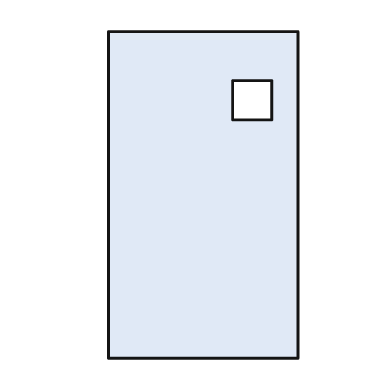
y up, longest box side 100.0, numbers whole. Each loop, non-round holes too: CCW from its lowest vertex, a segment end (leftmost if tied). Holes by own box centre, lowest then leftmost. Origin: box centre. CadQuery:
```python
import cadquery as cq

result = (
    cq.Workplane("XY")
    .moveTo(-29.0, -50.0)
    .lineTo(29.0, -50.0)
    .lineTo(29.0, 50.0)
    .lineTo(-29.0, 50.0)
    .close()
    .moveTo(9.0, 23.0)
    .lineTo(21.0, 23.0)
    .lineTo(21.0, 35.0)
    .lineTo(9.0, 35.0)
    .close()
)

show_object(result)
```